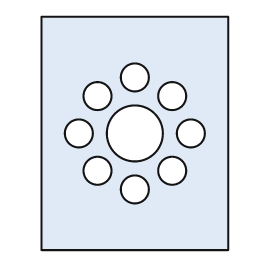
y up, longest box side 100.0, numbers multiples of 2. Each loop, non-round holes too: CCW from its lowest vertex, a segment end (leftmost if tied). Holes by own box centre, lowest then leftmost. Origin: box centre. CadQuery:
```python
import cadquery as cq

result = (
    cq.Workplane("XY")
    .moveTo(-40.0, -50.0)
    .lineTo(40.0, -50.0)
    .lineTo(40.0, 50.0)
    .lineTo(-40.0, 50.0)
    .close()
    .moveTo(0.0, -24.0)
    .circle(6.0)
    .moveTo(-16.0, -16.0)
    .circle(6.0)
    .moveTo(16.0, -16.0)
    .circle(6.0)
    .moveTo(-24.0, 0.0)
    .circle(6.0)
    .moveTo(0.0, 0.0)
    .circle(12.0)
    .moveTo(24.0, 0.0)
    .circle(6.0)
    .moveTo(-16.0, 16.0)
    .circle(6.0)
    .moveTo(16.0, 16.0)
    .circle(6.0)
    .moveTo(0.0, 24.0)
    .circle(6.0)
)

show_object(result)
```